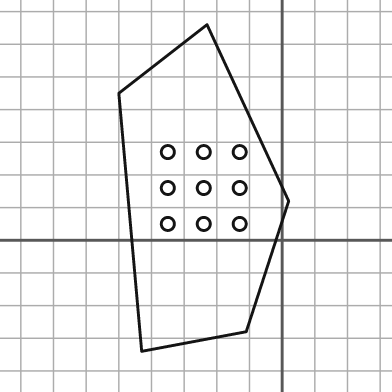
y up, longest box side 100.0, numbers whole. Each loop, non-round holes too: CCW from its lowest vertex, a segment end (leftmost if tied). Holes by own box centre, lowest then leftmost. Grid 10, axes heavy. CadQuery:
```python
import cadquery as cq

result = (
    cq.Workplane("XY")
    .moveTo(-43.0, -34.0)
    .lineTo(-11.0, -28.0)
    .lineTo(2.0, 12.0)
    .lineTo(-23.0, 66.0)
    .lineTo(-50.0, 45.0)
    .close()
    .moveTo(-35.0, 5.0)
    .circle(2.0)
    .moveTo(-24.0, 5.0)
    .circle(2.0)
    .moveTo(-13.0, 5.0)
    .circle(2.0)
    .moveTo(-35.0, 16.0)
    .circle(2.0)
    .moveTo(-24.0, 16.0)
    .circle(2.0)
    .moveTo(-13.0, 16.0)
    .circle(2.0)
    .moveTo(-35.0, 27.0)
    .circle(2.0)
    .moveTo(-24.0, 27.0)
    .circle(2.0)
    .moveTo(-13.0, 27.0)
    .circle(2.0)
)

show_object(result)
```